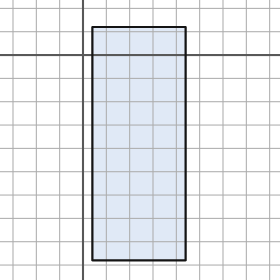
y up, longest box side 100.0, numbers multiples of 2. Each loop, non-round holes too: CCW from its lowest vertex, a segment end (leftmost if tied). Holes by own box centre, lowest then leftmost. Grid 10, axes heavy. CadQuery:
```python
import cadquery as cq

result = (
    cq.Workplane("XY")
    .moveTo(4.0, -88.0)
    .lineTo(44.0, -88.0)
    .lineTo(44.0, 12.0)
    .lineTo(4.0, 12.0)
    .close()
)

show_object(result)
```